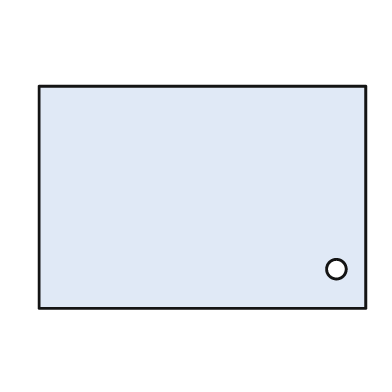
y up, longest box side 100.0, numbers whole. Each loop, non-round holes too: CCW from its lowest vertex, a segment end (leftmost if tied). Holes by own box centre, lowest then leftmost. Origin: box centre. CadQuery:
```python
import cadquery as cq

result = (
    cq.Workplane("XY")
    .moveTo(-50.0, -34.0)
    .lineTo(50.0, -34.0)
    .lineTo(50.0, 34.0)
    .lineTo(-50.0, 34.0)
    .close()
    .moveTo(41.0, -22.0)
    .circle(3.0)
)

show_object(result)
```